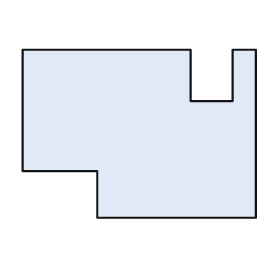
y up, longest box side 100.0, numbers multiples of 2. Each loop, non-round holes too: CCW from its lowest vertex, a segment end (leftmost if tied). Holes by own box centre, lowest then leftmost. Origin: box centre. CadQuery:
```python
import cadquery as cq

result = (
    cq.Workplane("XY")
    .moveTo(-18.0, -36.0)
    .lineTo(50.0, -36.0)
    .lineTo(50.0, 36.0)
    .lineTo(40.0, 36.0)
    .lineTo(40.0, 14.0)
    .lineTo(22.0, 14.0)
    .lineTo(22.0, 36.0)
    .lineTo(-50.0, 36.0)
    .lineTo(-50.0, -16.0)
    .lineTo(-18.0, -16.0)
    .close()
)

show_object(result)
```